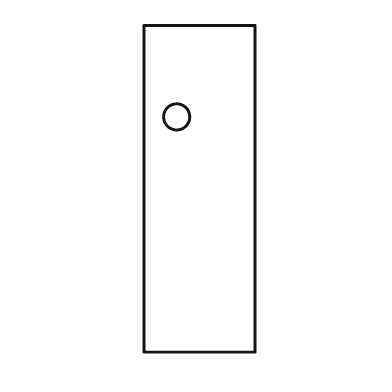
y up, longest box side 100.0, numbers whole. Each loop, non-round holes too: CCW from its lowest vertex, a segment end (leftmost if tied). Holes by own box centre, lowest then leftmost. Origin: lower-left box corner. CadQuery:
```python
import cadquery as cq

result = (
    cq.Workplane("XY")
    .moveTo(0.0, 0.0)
    .lineTo(34.0, 0.0)
    .lineTo(34.0, 100.0)
    .lineTo(0.0, 100.0)
    .close()
    .moveTo(10.0, 72.0)
    .circle(4.0)
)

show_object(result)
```